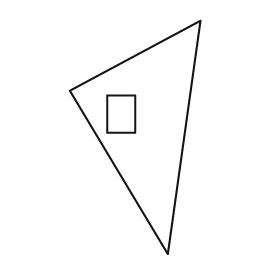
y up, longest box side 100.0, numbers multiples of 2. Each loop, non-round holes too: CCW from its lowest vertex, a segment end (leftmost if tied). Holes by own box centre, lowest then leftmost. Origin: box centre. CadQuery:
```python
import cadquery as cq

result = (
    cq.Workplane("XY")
    .moveTo(14.0, -50.0)
    .lineTo(28.0, 50.0)
    .lineTo(-28.0, 20.0)
    .close()
    .moveTo(-12.0, 2.0)
    .lineTo(0.0, 2.0)
    .lineTo(0.0, 18.0)
    .lineTo(-12.0, 18.0)
    .close()
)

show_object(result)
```